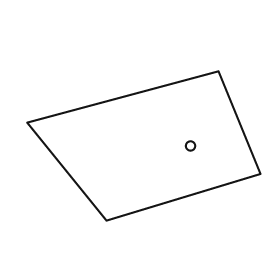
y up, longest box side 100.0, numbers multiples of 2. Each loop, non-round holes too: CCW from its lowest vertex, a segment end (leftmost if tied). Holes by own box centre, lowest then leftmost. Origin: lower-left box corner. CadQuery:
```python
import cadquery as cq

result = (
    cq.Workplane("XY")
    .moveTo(34.0, 0.0)
    .lineTo(100.0, 20.0)
    .lineTo(82.0, 64.0)
    .lineTo(0.0, 42.0)
    .close()
    .moveTo(70.0, 32.0)
    .circle(2.0)
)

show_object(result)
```